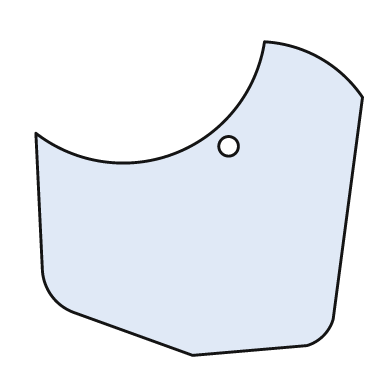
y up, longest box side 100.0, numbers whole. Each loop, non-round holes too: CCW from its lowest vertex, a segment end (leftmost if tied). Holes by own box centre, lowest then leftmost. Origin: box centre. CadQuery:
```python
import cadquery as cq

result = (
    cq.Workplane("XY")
    .moveTo(-2.0, -48.0)
    .lineTo(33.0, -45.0)
    .threePointArc((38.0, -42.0), (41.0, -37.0))
    .lineTo(50.0, 31.0)
    .threePointArc((37.0, 43.0), (20.0, 48.0))
    .threePointArc((-7.0, 14.0), (-50.0, 20.0))
    .lineTo(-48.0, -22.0)
    .threePointArc((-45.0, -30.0), (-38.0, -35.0))
    .close()
    .moveTo(9.0, 16.0)
    .circle(3.0)
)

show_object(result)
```